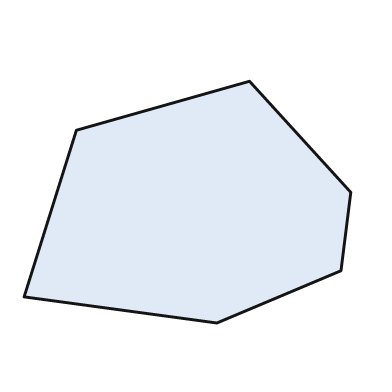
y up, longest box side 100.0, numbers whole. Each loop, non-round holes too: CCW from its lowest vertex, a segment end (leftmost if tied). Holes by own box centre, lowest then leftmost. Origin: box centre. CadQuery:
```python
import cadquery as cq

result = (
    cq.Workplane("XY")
    .moveTo(9.0, -37.0)
    .lineTo(47.0, -21.0)
    .lineTo(50.0, 3.0)
    .lineTo(19.0, 37.0)
    .lineTo(-34.0, 22.0)
    .lineTo(-50.0, -29.0)
    .close()
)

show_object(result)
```